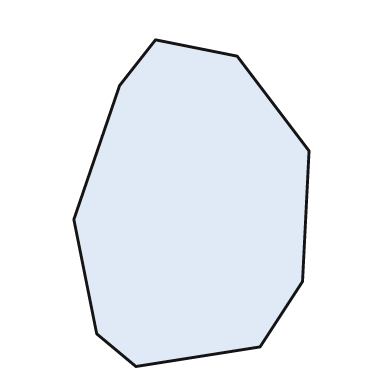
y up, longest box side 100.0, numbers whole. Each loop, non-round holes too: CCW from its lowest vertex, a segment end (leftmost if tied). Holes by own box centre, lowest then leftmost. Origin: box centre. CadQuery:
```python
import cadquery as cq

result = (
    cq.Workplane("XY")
    .moveTo(-17.0, -50.0)
    .lineTo(21.0, -44.0)
    .lineTo(34.0, -24.0)
    .lineTo(36.0, 16.0)
    .lineTo(14.0, 45.0)
    .lineTo(-11.0, 50.0)
    .lineTo(-22.0, 36.0)
    .lineTo(-36.0, -5.0)
    .lineTo(-29.0, -40.0)
    .close()
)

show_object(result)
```